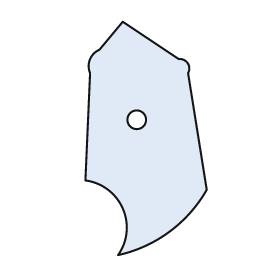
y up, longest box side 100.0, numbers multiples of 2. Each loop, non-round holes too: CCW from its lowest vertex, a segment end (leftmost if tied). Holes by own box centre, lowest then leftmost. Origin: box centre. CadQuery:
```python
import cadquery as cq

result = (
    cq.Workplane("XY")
    .moveTo(-12.0, -50.0)
    .threePointArc((10.0, -40.0), (26.0, -22.0))
    .lineTo(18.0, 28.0)
    .threePointArc((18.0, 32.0), (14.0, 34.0))
    .lineTo(-10.0, 50.0)
    .lineTo(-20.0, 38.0)
    .threePointArc((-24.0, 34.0), (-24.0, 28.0))
    .lineTo(-26.0, -18.0)
    .threePointArc((-10.0, -30.0), (-12.0, -50.0))
    .close()
    .moveTo(-4.0, 8.0)
    .circle(4.0)
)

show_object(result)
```